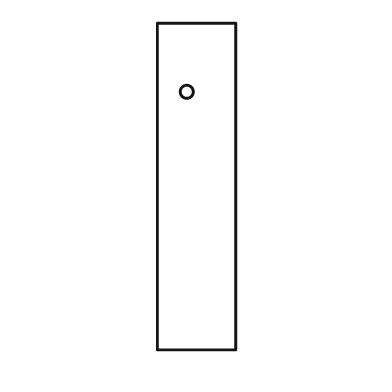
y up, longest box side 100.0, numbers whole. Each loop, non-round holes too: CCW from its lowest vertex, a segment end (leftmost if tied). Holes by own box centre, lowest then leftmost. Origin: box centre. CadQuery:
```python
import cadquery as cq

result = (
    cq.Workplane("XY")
    .moveTo(-12.0, -50.0)
    .lineTo(12.0, -50.0)
    .lineTo(12.0, 50.0)
    .lineTo(-12.0, 50.0)
    .close()
    .moveTo(-3.0, 29.0)
    .circle(2.0)
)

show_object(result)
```